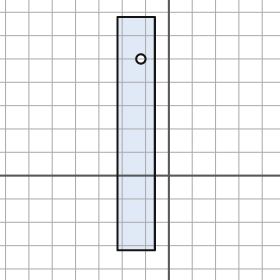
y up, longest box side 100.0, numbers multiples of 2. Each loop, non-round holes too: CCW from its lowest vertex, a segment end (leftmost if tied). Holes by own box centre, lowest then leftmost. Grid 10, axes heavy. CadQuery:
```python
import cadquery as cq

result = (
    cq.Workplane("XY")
    .moveTo(-22.0, -32.0)
    .lineTo(-6.0, -32.0)
    .lineTo(-6.0, 68.0)
    .lineTo(-22.0, 68.0)
    .close()
    .moveTo(-12.0, 50.0)
    .circle(2.0)
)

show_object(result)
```